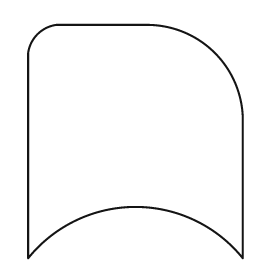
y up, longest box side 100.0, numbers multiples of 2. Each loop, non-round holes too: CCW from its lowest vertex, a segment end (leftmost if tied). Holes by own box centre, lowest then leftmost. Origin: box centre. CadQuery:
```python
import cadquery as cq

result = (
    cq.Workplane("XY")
    .moveTo(-46.0, -50.0)
    .threePointArc((0.0, -28.0), (46.0, -50.0))
    .lineTo(46.0, 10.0)
    .threePointArc((34.0, 38.0), (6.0, 50.0))
    .lineTo(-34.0, 50.0)
    .threePointArc((-42.0, 46.0), (-46.0, 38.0))
    .close()
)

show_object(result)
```